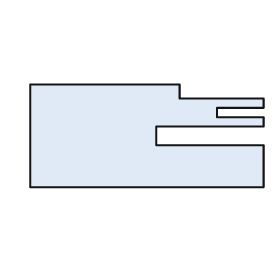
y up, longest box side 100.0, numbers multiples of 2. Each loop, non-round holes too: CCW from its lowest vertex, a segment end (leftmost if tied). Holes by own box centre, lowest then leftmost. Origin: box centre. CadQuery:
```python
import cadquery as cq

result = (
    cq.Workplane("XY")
    .moveTo(-50.0, -22.0)
    .lineTo(50.0, -22.0)
    .lineTo(50.0, -4.0)
    .lineTo(4.0, -4.0)
    .lineTo(4.0, 4.0)
    .lineTo(50.0, 4.0)
    .lineTo(50.0, 8.0)
    .lineTo(30.0, 8.0)
    .lineTo(30.0, 12.0)
    .lineTo(50.0, 12.0)
    .lineTo(50.0, 16.0)
    .lineTo(14.0, 16.0)
    .lineTo(14.0, 22.0)
    .lineTo(-50.0, 22.0)
    .close()
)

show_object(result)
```